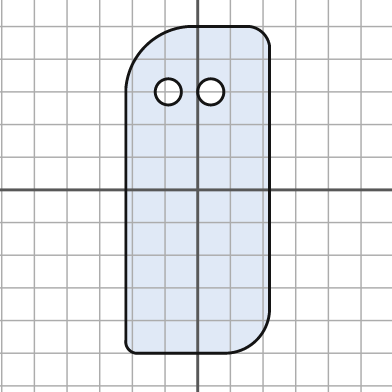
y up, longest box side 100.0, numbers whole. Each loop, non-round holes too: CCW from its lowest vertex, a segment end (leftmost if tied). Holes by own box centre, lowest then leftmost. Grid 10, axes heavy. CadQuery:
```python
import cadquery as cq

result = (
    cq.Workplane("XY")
    .moveTo(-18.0, -50.0)
    .lineTo(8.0, -50.0)
    .threePointArc((18.0, -46.0), (22.0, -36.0))
    .lineTo(22.0, 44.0)
    .threePointArc((20.0, 48.0), (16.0, 50.0))
    .lineTo(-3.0, 50.0)
    .threePointArc((-16.0, 44.0), (-22.0, 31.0))
    .lineTo(-22.0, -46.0)
    .threePointArc((-21.0, -49.0), (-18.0, -50.0))
    .close()
    .moveTo(-9.0, 30.0)
    .circle(4.0)
    .moveTo(4.0, 30.0)
    .circle(4.0)
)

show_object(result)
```